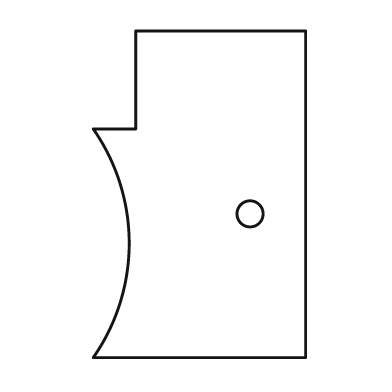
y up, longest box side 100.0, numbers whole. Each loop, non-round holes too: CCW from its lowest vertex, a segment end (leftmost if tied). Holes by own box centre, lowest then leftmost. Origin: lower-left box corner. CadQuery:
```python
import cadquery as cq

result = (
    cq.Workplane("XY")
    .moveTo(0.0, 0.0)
    .lineTo(65.0, 0.0)
    .lineTo(65.0, 100.0)
    .lineTo(13.0, 100.0)
    .lineTo(13.0, 70.0)
    .lineTo(0.0, 70.0)
    .threePointArc((11.0, 35.0), (0.0, 0.0))
    .close()
    .moveTo(48.0, 44.0)
    .circle(4.0)
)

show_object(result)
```